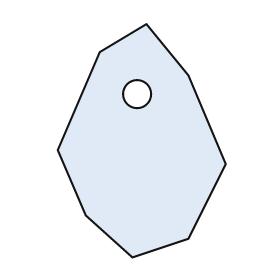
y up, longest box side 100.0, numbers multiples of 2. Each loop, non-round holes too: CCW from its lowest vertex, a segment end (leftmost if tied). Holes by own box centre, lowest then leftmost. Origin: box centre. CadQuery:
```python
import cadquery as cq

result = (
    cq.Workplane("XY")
    .moveTo(-4.0, -50.0)
    .lineTo(20.0, -42.0)
    .lineTo(36.0, -10.0)
    .lineTo(20.0, 28.0)
    .lineTo(2.0, 50.0)
    .lineTo(-18.0, 38.0)
    .lineTo(-36.0, -4.0)
    .lineTo(-24.0, -32.0)
    .close()
    .moveTo(-2.0, 20.0)
    .circle(6.0)
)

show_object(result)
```